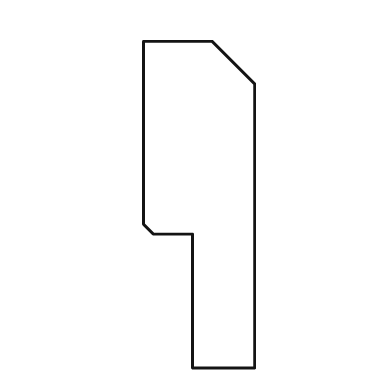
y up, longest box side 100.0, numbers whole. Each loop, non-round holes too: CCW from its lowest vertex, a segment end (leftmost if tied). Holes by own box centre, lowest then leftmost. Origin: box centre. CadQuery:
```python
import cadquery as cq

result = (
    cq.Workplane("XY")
    .moveTo(-2.0, -50.0)
    .lineTo(17.0, -50.0)
    .lineTo(17.0, 37.0)
    .lineTo(4.0, 50.0)
    .lineTo(-17.0, 50.0)
    .lineTo(-17.0, -6.0)
    .lineTo(-14.0, -9.0)
    .lineTo(-2.0, -9.0)
    .close()
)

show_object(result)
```